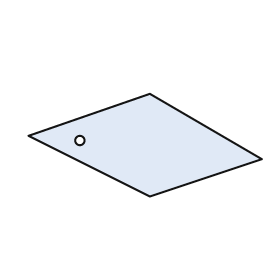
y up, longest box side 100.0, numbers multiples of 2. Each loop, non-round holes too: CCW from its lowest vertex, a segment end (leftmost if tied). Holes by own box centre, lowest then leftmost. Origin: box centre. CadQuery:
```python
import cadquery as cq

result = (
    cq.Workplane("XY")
    .moveTo(2.0, -22.0)
    .lineTo(50.0, -6.0)
    .lineTo(2.0, 22.0)
    .lineTo(-50.0, 4.0)
    .close()
    .moveTo(-28.0, 2.0)
    .circle(2.0)
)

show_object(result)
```